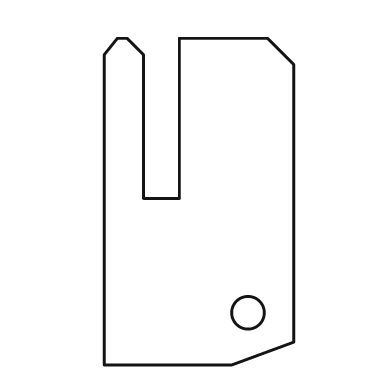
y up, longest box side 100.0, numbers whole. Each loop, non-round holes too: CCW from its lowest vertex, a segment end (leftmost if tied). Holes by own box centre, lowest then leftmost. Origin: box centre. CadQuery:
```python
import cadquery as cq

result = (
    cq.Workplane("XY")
    .moveTo(-29.0, -50.0)
    .lineTo(10.0, -50.0)
    .lineTo(29.0, -43.0)
    .lineTo(29.0, 42.0)
    .lineTo(21.0, 50.0)
    .lineTo(-6.0, 50.0)
    .lineTo(-6.0, 1.0)
    .lineTo(-17.0, 1.0)
    .lineTo(-17.0, 45.0)
    .lineTo(-22.0, 50.0)
    .lineTo(-25.0, 50.0)
    .lineTo(-29.0, 45.0)
    .close()
    .moveTo(15.0, -34.0)
    .circle(5.0)
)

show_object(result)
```